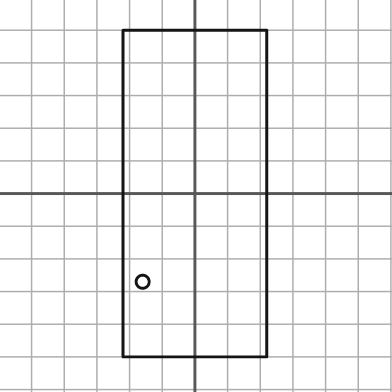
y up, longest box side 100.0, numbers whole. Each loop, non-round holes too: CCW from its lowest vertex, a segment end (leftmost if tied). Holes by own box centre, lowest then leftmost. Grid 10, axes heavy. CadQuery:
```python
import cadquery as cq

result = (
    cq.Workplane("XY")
    .moveTo(-22.0, -50.0)
    .lineTo(22.0, -50.0)
    .lineTo(22.0, 50.0)
    .lineTo(-22.0, 50.0)
    .close()
    .moveTo(-16.0, -27.0)
    .circle(2.0)
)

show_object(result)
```